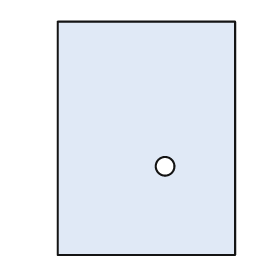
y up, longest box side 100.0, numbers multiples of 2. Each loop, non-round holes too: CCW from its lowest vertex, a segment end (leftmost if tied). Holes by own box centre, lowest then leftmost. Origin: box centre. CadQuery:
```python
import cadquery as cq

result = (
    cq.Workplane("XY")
    .moveTo(-38.0, -50.0)
    .lineTo(38.0, -50.0)
    .lineTo(38.0, 50.0)
    .lineTo(-38.0, 50.0)
    .close()
    .moveTo(8.0, -12.0)
    .circle(4.0)
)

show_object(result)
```